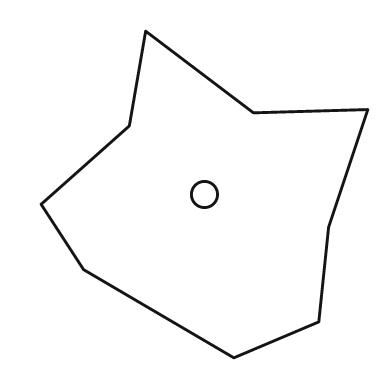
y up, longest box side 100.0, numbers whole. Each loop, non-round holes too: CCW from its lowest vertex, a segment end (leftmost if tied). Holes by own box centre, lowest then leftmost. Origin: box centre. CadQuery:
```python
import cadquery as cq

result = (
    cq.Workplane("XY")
    .moveTo(9.0, -50.0)
    .lineTo(35.0, -39.0)
    .lineTo(38.0, -10.0)
    .lineTo(50.0, 26.0)
    .lineTo(15.0, 25.0)
    .lineTo(-18.0, 50.0)
    .lineTo(-23.0, 21.0)
    .lineTo(-50.0, -3.0)
    .lineTo(-37.0, -23.0)
    .close()
    .moveTo(0.0, 0.0)
    .circle(4.0)
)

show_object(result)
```